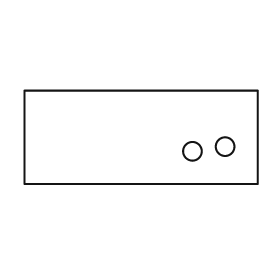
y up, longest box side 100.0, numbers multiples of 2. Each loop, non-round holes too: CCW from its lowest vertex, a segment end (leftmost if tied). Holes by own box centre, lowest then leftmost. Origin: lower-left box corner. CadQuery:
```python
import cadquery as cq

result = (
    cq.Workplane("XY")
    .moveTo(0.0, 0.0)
    .lineTo(100.0, 0.0)
    .lineTo(100.0, 40.0)
    .lineTo(0.0, 40.0)
    .close()
    .moveTo(72.0, 14.0)
    .circle(4.0)
    .moveTo(86.0, 16.0)
    .circle(4.0)
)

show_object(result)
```